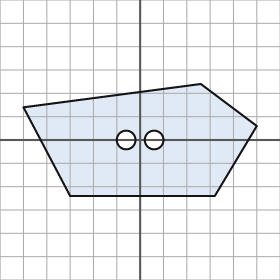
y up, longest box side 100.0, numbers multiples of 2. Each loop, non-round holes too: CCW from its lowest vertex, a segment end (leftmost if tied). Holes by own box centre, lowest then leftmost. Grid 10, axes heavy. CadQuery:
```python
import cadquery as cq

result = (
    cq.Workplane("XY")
    .moveTo(-30.0, -24.0)
    .lineTo(32.0, -24.0)
    .lineTo(50.0, 6.0)
    .lineTo(26.0, 24.0)
    .lineTo(-50.0, 14.0)
    .close()
    .moveTo(-6.0, 0.0)
    .circle(4.0)
    .moveTo(6.0, 0.0)
    .circle(4.0)
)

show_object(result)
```